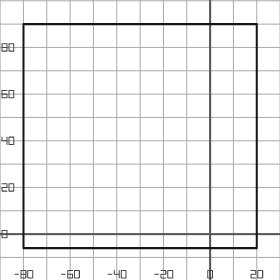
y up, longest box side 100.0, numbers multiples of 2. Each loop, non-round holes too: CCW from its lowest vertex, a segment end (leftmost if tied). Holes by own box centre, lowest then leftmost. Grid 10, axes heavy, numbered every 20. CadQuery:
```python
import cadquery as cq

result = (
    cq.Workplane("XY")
    .moveTo(-80.0, -6.0)
    .lineTo(20.0, -6.0)
    .lineTo(20.0, 90.0)
    .lineTo(-80.0, 90.0)
    .close()
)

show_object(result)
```